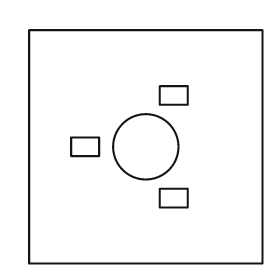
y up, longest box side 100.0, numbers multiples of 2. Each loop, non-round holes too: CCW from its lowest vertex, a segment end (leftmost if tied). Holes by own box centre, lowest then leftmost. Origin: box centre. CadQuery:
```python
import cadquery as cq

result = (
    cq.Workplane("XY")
    .moveTo(-50.0, -50.0)
    .lineTo(50.0, -50.0)
    .lineTo(50.0, 50.0)
    .lineTo(-50.0, 50.0)
    .close()
    .moveTo(6.0, -26.0)
    .lineTo(18.0, -26.0)
    .lineTo(18.0, -18.0)
    .lineTo(6.0, -18.0)
    .close()
    .moveTo(-32.0, -4.0)
    .lineTo(-20.0, -4.0)
    .lineTo(-20.0, 4.0)
    .lineTo(-32.0, 4.0)
    .close()
    .moveTo(0.0, 0.0)
    .circle(14.0)
    .moveTo(6.0, 18.0)
    .lineTo(18.0, 18.0)
    .lineTo(18.0, 26.0)
    .lineTo(6.0, 26.0)
    .close()
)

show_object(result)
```